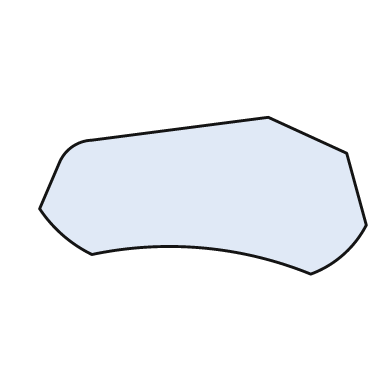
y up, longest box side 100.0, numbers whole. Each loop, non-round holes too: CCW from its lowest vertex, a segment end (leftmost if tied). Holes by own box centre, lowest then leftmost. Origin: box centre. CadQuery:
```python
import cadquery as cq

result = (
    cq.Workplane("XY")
    .moveTo(33.0, -24.0)
    .threePointArc((43.0, -18.0), (50.0, -9.0))
    .lineTo(44.0, 13.0)
    .lineTo(20.0, 24.0)
    .lineTo(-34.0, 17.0)
    .threePointArc((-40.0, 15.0), (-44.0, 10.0))
    .lineTo(-50.0, -4.0)
    .threePointArc((-43.0, -12.0), (-34.0, -18.0))
    .threePointArc((0.0, -16.0), (33.0, -24.0))
    .close()
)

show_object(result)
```